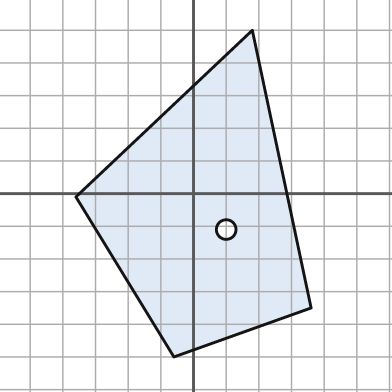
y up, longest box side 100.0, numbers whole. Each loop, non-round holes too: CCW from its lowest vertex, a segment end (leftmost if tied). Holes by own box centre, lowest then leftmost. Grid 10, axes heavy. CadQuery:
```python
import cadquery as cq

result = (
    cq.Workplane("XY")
    .moveTo(-6.0, -50.0)
    .lineTo(36.0, -35.0)
    .lineTo(18.0, 50.0)
    .lineTo(-36.0, -1.0)
    .close()
    .moveTo(10.0, -11.0)
    .circle(3.0)
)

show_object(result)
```